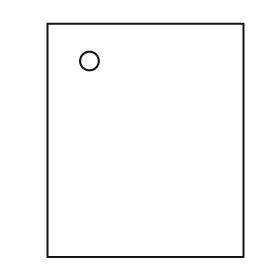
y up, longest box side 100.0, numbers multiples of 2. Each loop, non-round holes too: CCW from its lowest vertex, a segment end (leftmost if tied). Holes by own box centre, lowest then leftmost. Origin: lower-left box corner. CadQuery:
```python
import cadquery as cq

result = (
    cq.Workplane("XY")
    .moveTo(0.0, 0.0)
    .lineTo(84.0, 0.0)
    .lineTo(84.0, 100.0)
    .lineTo(0.0, 100.0)
    .close()
    .moveTo(18.0, 84.0)
    .circle(4.0)
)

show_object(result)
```